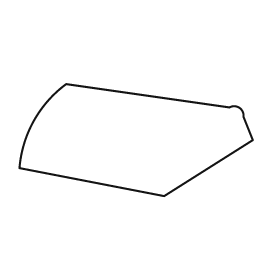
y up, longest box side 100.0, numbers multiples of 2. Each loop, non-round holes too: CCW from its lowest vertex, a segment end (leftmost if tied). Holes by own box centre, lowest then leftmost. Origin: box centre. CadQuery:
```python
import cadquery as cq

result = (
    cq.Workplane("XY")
    .moveTo(12.0, -24.0)
    .lineTo(50.0, 0.0)
    .lineTo(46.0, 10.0)
    .threePointArc((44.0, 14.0), (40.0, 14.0))
    .lineTo(-30.0, 24.0)
    .threePointArc((-44.0, 8.0), (-50.0, -12.0))
    .close()
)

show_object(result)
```